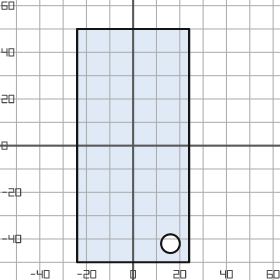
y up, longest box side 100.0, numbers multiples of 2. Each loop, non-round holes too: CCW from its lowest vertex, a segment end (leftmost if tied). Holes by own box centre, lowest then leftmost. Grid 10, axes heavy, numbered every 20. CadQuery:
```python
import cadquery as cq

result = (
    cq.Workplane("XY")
    .moveTo(-24.0, -50.0)
    .lineTo(24.0, -50.0)
    .lineTo(24.0, 50.0)
    .lineTo(-24.0, 50.0)
    .close()
    .moveTo(16.0, -42.0)
    .circle(4.0)
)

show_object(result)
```